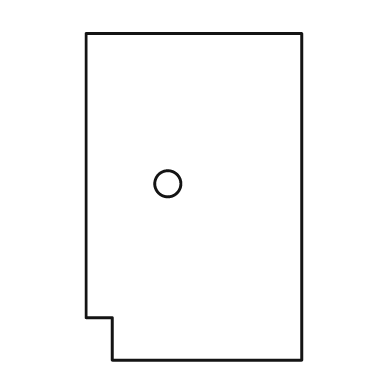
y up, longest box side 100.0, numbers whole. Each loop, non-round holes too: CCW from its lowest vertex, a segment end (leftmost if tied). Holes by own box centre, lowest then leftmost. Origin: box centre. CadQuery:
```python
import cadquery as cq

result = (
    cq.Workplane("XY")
    .moveTo(-25.0, -50.0)
    .lineTo(33.0, -50.0)
    .lineTo(33.0, 50.0)
    .lineTo(-33.0, 50.0)
    .lineTo(-33.0, -37.0)
    .lineTo(-25.0, -37.0)
    .close()
    .moveTo(-8.0, 4.0)
    .circle(4.0)
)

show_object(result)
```